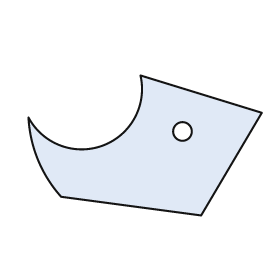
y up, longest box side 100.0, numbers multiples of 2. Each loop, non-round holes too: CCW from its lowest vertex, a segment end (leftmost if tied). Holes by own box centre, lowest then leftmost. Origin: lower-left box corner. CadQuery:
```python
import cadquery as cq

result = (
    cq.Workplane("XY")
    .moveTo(74.0, 0.0)
    .lineTo(100.0, 44.0)
    .lineTo(48.0, 60.0)
    .threePointArc((32.0, 30.0), (0.0, 42.0))
    .threePointArc((4.0, 24.0), (14.0, 8.0))
    .close()
    .moveTo(66.0, 36.0)
    .circle(4.0)
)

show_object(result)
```